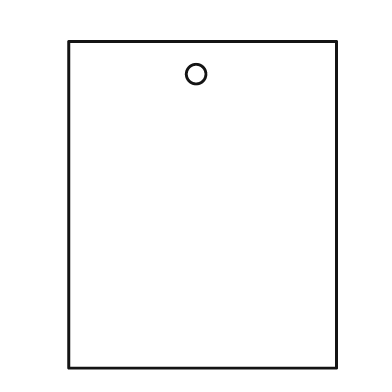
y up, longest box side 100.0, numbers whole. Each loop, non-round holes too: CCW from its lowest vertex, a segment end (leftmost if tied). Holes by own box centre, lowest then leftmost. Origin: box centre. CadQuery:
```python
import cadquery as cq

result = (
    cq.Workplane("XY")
    .moveTo(-41.0, -50.0)
    .lineTo(41.0, -50.0)
    .lineTo(41.0, 50.0)
    .lineTo(-41.0, 50.0)
    .close()
    .moveTo(-2.0, 40.0)
    .circle(3.0)
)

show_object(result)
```